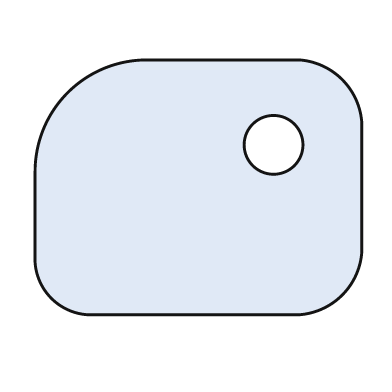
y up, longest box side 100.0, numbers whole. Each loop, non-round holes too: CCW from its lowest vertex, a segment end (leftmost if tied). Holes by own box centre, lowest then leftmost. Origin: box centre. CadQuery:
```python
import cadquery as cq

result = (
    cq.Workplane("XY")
    .moveTo(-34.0, -39.0)
    .lineTo(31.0, -39.0)
    .threePointArc((44.0, -33.0), (50.0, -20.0))
    .lineTo(50.0, 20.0)
    .threePointArc((44.0, 33.0), (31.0, 39.0))
    .lineTo(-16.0, 39.0)
    .threePointArc((-40.0, 29.0), (-50.0, 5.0))
    .lineTo(-50.0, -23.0)
    .threePointArc((-45.0, -34.0), (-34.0, -39.0))
    .close()
    .moveTo(23.0, 13.0)
    .circle(9.0)
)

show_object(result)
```